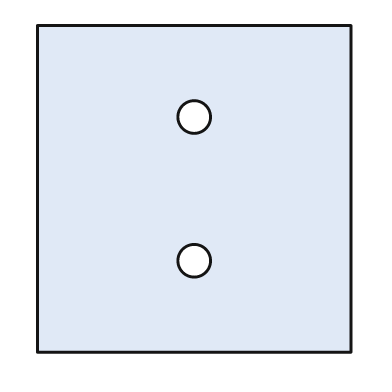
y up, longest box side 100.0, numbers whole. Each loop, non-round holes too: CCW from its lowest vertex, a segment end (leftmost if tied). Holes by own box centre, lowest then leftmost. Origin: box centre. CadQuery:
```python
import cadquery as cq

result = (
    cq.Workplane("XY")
    .moveTo(-48.0, -50.0)
    .lineTo(48.0, -50.0)
    .lineTo(48.0, 50.0)
    .lineTo(-48.0, 50.0)
    .close()
    .moveTo(0.0, -22.0)
    .circle(5.0)
    .moveTo(0.0, 22.0)
    .circle(5.0)
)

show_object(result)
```